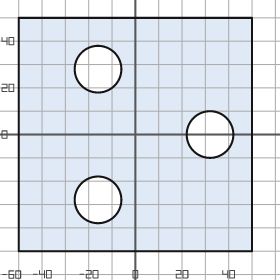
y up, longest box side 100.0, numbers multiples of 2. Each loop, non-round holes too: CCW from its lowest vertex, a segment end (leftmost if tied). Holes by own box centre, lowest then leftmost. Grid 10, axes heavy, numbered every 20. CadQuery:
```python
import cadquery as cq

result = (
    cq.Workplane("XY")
    .moveTo(-50.0, -50.0)
    .lineTo(50.0, -50.0)
    .lineTo(50.0, 50.0)
    .lineTo(-50.0, 50.0)
    .close()
    .moveTo(-16.0, -28.0)
    .circle(10.0)
    .moveTo(32.0, 0.0)
    .circle(10.0)
    .moveTo(-16.0, 28.0)
    .circle(10.0)
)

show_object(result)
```